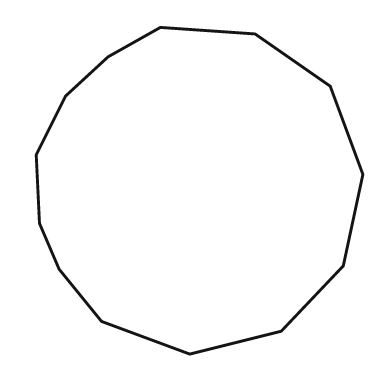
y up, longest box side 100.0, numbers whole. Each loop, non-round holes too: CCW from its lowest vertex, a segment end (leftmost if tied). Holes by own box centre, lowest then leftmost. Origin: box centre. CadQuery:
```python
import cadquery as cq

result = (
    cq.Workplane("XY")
    .moveTo(-3.0, -50.0)
    .lineTo(25.0, -43.0)
    .lineTo(44.0, -23.0)
    .lineTo(50.0, 5.0)
    .lineTo(40.0, 32.0)
    .lineTo(17.0, 48.0)
    .lineTo(-12.0, 50.0)
    .lineTo(-28.0, 41.0)
    .lineTo(-41.0, 29.0)
    .lineTo(-50.0, 11.0)
    .lineTo(-49.0, -10.0)
    .lineTo(-43.0, -24.0)
    .lineTo(-30.0, -40.0)
    .close()
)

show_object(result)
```